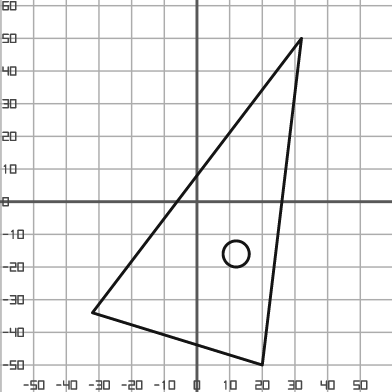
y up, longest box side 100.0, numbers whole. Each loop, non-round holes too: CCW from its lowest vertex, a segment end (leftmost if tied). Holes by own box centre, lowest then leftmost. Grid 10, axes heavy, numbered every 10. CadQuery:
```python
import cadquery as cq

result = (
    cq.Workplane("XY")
    .moveTo(20.0, -50.0)
    .lineTo(32.0, 50.0)
    .lineTo(-32.0, -34.0)
    .close()
    .moveTo(12.0, -16.0)
    .circle(4.0)
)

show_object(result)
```